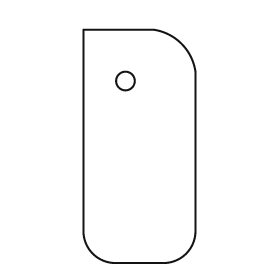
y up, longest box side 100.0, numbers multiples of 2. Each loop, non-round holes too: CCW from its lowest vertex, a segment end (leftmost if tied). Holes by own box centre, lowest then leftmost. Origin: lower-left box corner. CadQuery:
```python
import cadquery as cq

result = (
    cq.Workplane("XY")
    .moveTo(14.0, 0.0)
    .lineTo(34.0, 0.0)
    .threePointArc((44.0, 4.0), (48.0, 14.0))
    .lineTo(48.0, 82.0)
    .threePointArc((42.0, 94.0), (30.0, 100.0))
    .lineTo(0.0, 100.0)
    .lineTo(0.0, 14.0)
    .threePointArc((4.0, 4.0), (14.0, 0.0))
    .close()
    .moveTo(18.0, 78.0)
    .circle(4.0)
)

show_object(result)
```